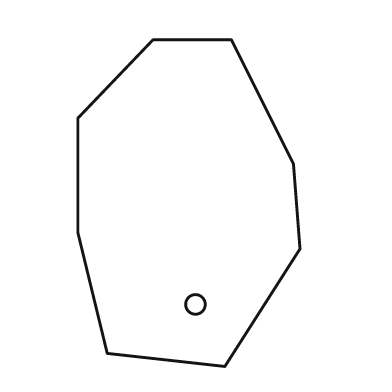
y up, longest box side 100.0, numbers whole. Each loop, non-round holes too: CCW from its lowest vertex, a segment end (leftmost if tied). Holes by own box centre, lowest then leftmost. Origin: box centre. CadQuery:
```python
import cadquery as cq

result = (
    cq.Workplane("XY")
    .moveTo(11.0, -50.0)
    .lineTo(34.0, -14.0)
    .lineTo(32.0, 12.0)
    .lineTo(13.0, 50.0)
    .lineTo(-11.0, 50.0)
    .lineTo(-34.0, 26.0)
    .lineTo(-34.0, -9.0)
    .lineTo(-25.0, -46.0)
    .close()
    .moveTo(2.0, -31.0)
    .circle(3.0)
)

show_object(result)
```